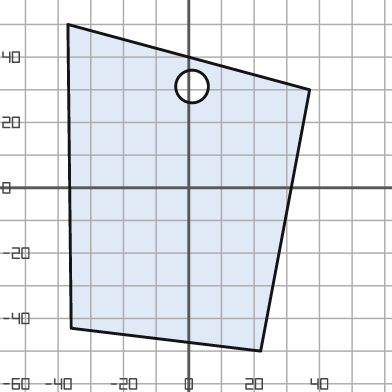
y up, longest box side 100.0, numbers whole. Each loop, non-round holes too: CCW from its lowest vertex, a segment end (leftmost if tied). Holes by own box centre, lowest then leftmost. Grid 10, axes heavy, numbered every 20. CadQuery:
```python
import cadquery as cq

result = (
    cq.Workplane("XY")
    .moveTo(22.0, -50.0)
    .lineTo(37.0, 30.0)
    .lineTo(-37.0, 50.0)
    .lineTo(-36.0, -43.0)
    .close()
    .moveTo(1.0, 31.0)
    .circle(5.0)
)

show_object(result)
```